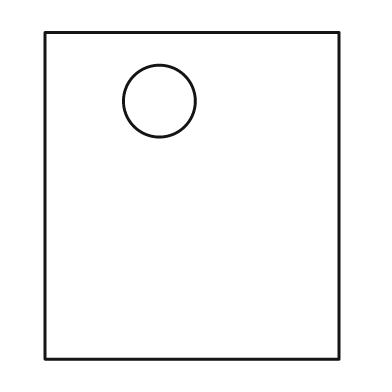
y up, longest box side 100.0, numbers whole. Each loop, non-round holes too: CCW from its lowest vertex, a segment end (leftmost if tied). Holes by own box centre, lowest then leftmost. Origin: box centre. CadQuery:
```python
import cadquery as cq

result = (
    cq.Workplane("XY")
    .moveTo(-45.0, -50.0)
    .lineTo(45.0, -50.0)
    .lineTo(45.0, 50.0)
    .lineTo(-45.0, 50.0)
    .close()
    .moveTo(-10.0, 29.0)
    .circle(11.0)
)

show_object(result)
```